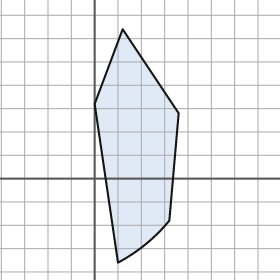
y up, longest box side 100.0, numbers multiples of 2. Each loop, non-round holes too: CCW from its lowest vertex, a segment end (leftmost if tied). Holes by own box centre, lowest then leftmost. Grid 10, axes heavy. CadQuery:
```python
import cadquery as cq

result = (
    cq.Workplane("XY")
    .moveTo(10.0, -36.0)
    .threePointArc((22.0, -28.0), (32.0, -18.0))
    .lineTo(36.0, 28.0)
    .lineTo(12.0, 64.0)
    .lineTo(0.0, 32.0)
    .close()
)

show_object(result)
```